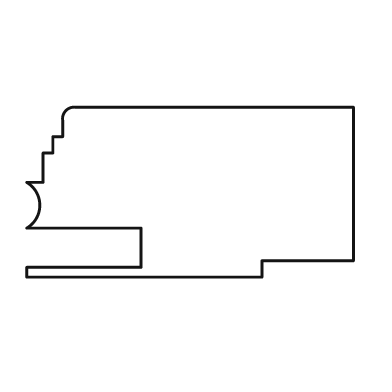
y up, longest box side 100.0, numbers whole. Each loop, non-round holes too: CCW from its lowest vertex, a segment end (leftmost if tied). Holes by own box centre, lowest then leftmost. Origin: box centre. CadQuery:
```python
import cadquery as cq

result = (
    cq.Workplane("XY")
    .moveTo(-50.0, -26.0)
    .lineTo(22.0, -26.0)
    .lineTo(22.0, -21.0)
    .lineTo(50.0, -21.0)
    .lineTo(50.0, 26.0)
    .lineTo(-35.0, 26.0)
    .threePointArc((-38.0, 25.0), (-39.0, 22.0))
    .lineTo(-39.0, 17.0)
    .lineTo(-42.0, 17.0)
    .lineTo(-42.0, 12.0)
    .lineTo(-45.0, 12.0)
    .lineTo(-45.0, 3.0)
    .lineTo(-50.0, 3.0)
    .threePointArc((-46.0, -4.0), (-50.0, -11.0))
    .lineTo(-15.0, -11.0)
    .lineTo(-15.0, -23.0)
    .lineTo(-50.0, -23.0)
    .close()
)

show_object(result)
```